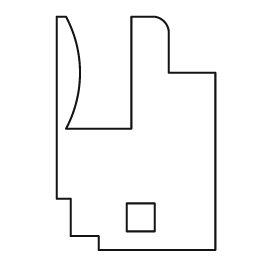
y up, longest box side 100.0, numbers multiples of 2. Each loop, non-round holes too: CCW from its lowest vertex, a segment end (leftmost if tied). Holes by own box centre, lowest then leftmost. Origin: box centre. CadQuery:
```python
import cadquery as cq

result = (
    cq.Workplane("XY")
    .moveTo(-16.0, -50.0)
    .lineTo(34.0, -50.0)
    .lineTo(34.0, 26.0)
    .lineTo(14.0, 26.0)
    .lineTo(14.0, 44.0)
    .threePointArc((12.0, 48.0), (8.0, 50.0))
    .lineTo(-2.0, 50.0)
    .lineTo(-2.0, 2.0)
    .lineTo(-30.0, 2.0)
    .threePointArc((-24.0, 26.0), (-30.0, 50.0))
    .lineTo(-34.0, 50.0)
    .lineTo(-34.0, -28.0)
    .lineTo(-28.0, -28.0)
    .lineTo(-28.0, -44.0)
    .lineTo(-16.0, -44.0)
    .close()
    .moveTo(-4.0, -42.0)
    .lineTo(8.0, -42.0)
    .lineTo(8.0, -30.0)
    .lineTo(-4.0, -30.0)
    .close()
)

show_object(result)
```